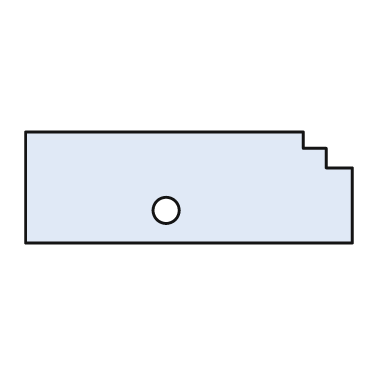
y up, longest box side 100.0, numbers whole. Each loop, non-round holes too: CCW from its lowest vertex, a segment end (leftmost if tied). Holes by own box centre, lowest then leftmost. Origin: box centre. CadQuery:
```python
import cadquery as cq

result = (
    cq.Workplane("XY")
    .moveTo(-50.0, -17.0)
    .lineTo(50.0, -17.0)
    .lineTo(50.0, 6.0)
    .lineTo(42.0, 6.0)
    .lineTo(42.0, 12.0)
    .lineTo(35.0, 12.0)
    .lineTo(35.0, 17.0)
    .lineTo(-50.0, 17.0)
    .close()
    .moveTo(-7.0, -7.0)
    .circle(4.0)
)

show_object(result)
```